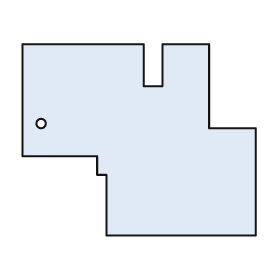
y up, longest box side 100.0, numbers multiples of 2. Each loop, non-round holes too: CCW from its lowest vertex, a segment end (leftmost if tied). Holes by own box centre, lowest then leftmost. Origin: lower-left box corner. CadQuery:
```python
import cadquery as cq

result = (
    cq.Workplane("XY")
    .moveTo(36.0, 0.0)
    .lineTo(100.0, 0.0)
    .lineTo(100.0, 46.0)
    .lineTo(80.0, 46.0)
    .lineTo(80.0, 82.0)
    .lineTo(60.0, 82.0)
    .lineTo(60.0, 64.0)
    .lineTo(52.0, 64.0)
    .lineTo(52.0, 82.0)
    .lineTo(0.0, 82.0)
    .lineTo(0.0, 34.0)
    .lineTo(32.0, 34.0)
    .lineTo(32.0, 26.0)
    .lineTo(36.0, 26.0)
    .close()
    .moveTo(8.0, 48.0)
    .circle(2.0)
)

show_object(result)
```